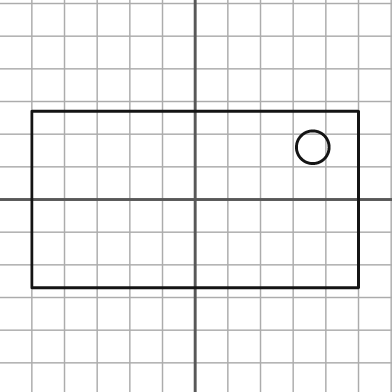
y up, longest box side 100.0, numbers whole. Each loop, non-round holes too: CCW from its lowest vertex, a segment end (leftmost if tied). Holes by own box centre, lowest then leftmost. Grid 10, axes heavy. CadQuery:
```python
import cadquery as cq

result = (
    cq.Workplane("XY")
    .moveTo(-50.0, -27.0)
    .lineTo(50.0, -27.0)
    .lineTo(50.0, 27.0)
    .lineTo(-50.0, 27.0)
    .close()
    .moveTo(36.0, 16.0)
    .circle(5.0)
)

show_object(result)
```